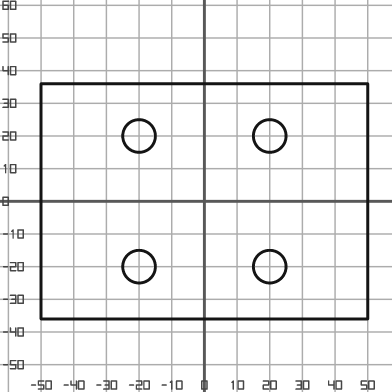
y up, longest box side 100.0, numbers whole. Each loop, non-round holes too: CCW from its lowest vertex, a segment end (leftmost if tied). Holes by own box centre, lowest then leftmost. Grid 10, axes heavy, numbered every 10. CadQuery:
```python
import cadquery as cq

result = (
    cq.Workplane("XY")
    .moveTo(-50.0, -36.0)
    .lineTo(50.0, -36.0)
    .lineTo(50.0, 36.0)
    .lineTo(-50.0, 36.0)
    .close()
    .moveTo(-20.0, -20.0)
    .circle(5.0)
    .moveTo(20.0, -20.0)
    .circle(5.0)
    .moveTo(-20.0, 20.0)
    .circle(5.0)
    .moveTo(20.0, 20.0)
    .circle(5.0)
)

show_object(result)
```